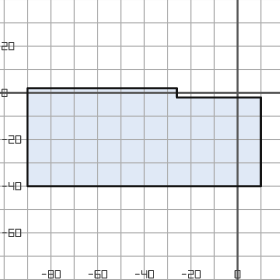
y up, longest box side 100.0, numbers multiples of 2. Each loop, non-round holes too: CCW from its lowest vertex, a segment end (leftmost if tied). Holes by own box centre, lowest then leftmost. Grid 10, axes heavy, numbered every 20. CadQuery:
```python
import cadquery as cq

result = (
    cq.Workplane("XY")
    .moveTo(-90.0, -40.0)
    .lineTo(10.0, -40.0)
    .lineTo(10.0, -2.0)
    .lineTo(-26.0, -2.0)
    .lineTo(-26.0, 2.0)
    .lineTo(-90.0, 2.0)
    .close()
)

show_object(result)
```